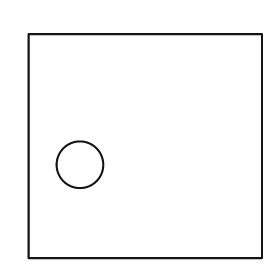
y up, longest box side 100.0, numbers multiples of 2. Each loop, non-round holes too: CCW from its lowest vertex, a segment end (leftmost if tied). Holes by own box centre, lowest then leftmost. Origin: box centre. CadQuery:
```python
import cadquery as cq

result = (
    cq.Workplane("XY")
    .moveTo(-50.0, -48.0)
    .lineTo(50.0, -48.0)
    .lineTo(50.0, 48.0)
    .lineTo(-50.0, 48.0)
    .close()
    .moveTo(-28.0, -8.0)
    .circle(10.0)
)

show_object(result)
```